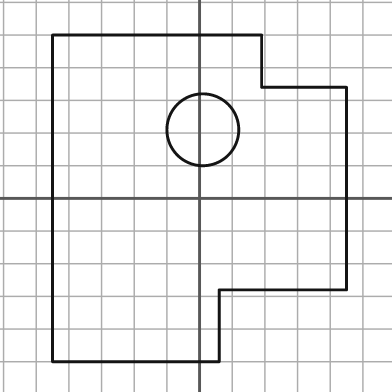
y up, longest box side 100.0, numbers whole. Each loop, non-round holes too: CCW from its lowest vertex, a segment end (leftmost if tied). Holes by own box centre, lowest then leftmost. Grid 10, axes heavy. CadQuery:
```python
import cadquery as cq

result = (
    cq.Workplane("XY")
    .moveTo(-45.0, -50.0)
    .lineTo(6.0, -50.0)
    .lineTo(6.0, -28.0)
    .lineTo(45.0, -28.0)
    .lineTo(45.0, 34.0)
    .lineTo(19.0, 34.0)
    .lineTo(19.0, 50.0)
    .lineTo(-45.0, 50.0)
    .close()
    .moveTo(1.0, 21.0)
    .circle(11.0)
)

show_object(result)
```